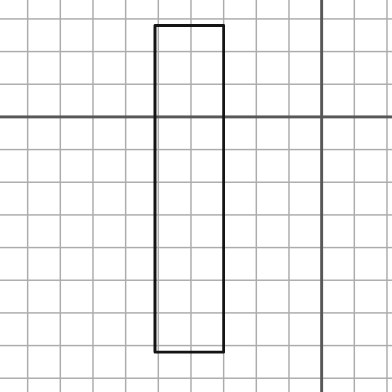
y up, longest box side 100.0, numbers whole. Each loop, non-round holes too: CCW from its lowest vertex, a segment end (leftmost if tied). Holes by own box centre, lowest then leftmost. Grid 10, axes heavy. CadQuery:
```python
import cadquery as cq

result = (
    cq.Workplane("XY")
    .moveTo(-51.0, -72.0)
    .lineTo(-30.0, -72.0)
    .lineTo(-30.0, 28.0)
    .lineTo(-51.0, 28.0)
    .close()
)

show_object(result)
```